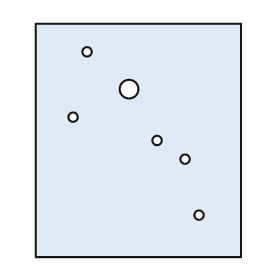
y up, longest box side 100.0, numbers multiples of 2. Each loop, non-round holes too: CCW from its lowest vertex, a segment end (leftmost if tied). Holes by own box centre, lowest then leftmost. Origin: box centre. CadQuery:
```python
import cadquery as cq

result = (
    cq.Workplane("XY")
    .moveTo(-44.0, -50.0)
    .lineTo(44.0, -50.0)
    .lineTo(44.0, 50.0)
    .lineTo(-44.0, 50.0)
    .close()
    .moveTo(26.0, -32.0)
    .circle(2.0)
    .moveTo(20.0, -8.0)
    .circle(2.0)
    .moveTo(8.0, 0.0)
    .circle(2.0)
    .moveTo(-28.0, 10.0)
    .circle(2.0)
    .moveTo(-4.0, 22.0)
    .circle(4.0)
    .moveTo(-22.0, 38.0)
    .circle(2.0)
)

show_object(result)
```